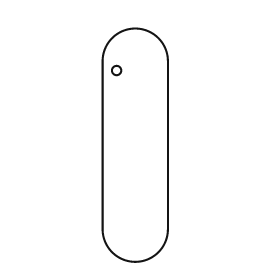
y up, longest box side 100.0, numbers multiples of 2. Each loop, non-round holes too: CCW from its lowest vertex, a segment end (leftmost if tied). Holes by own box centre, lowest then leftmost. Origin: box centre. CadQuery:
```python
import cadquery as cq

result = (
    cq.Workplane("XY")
    .moveTo(-14.0, -36.0)
    .threePointArc((0.0, -50.0), (14.0, -36.0))
    .lineTo(14.0, 36.0)
    .threePointArc((0.0, 50.0), (-14.0, 36.0))
    .close()
    .moveTo(-8.0, 32.0)
    .circle(2.0)
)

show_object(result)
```